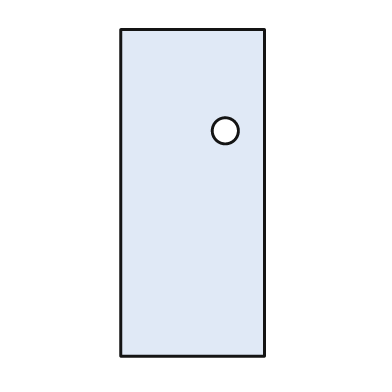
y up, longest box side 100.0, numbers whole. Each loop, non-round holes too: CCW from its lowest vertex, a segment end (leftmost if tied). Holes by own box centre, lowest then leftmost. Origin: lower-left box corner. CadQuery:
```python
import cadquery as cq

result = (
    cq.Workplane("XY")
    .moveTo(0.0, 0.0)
    .lineTo(44.0, 0.0)
    .lineTo(44.0, 100.0)
    .lineTo(0.0, 100.0)
    .close()
    .moveTo(32.0, 69.0)
    .circle(4.0)
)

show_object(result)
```